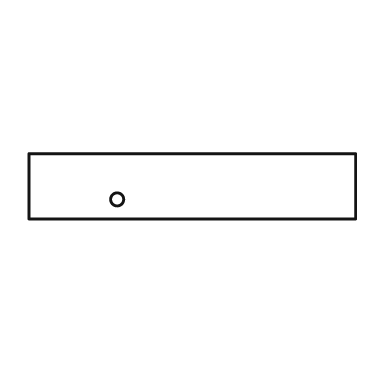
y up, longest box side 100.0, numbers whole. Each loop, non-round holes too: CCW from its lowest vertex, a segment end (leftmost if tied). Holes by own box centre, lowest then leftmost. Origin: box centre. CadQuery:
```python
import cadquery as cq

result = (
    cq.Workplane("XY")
    .moveTo(-50.0, -10.0)
    .lineTo(50.0, -10.0)
    .lineTo(50.0, 10.0)
    .lineTo(-50.0, 10.0)
    .close()
    .moveTo(-23.0, -4.0)
    .circle(2.0)
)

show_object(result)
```